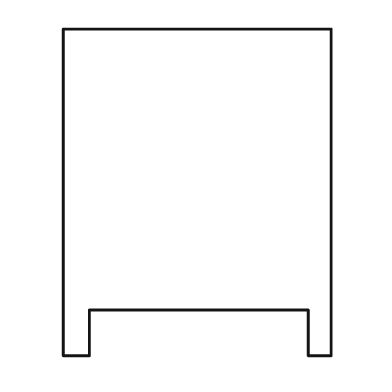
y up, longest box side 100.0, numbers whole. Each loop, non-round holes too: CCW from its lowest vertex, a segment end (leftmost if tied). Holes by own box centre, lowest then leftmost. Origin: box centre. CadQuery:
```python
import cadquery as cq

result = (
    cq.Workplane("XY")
    .moveTo(-41.0, -50.0)
    .lineTo(-33.0, -50.0)
    .lineTo(-33.0, -36.0)
    .lineTo(34.0, -36.0)
    .lineTo(34.0, -50.0)
    .lineTo(41.0, -50.0)
    .lineTo(41.0, 50.0)
    .lineTo(-41.0, 50.0)
    .close()
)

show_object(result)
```